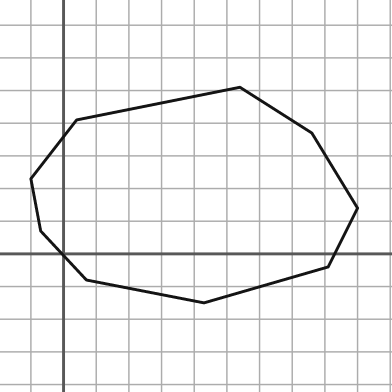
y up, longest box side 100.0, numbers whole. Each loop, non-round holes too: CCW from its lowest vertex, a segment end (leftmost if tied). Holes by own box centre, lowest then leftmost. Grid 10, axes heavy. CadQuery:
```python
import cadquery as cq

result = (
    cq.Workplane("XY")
    .moveTo(43.0, -15.0)
    .lineTo(81.0, -4.0)
    .lineTo(90.0, 14.0)
    .lineTo(76.0, 37.0)
    .lineTo(54.0, 51.0)
    .lineTo(4.0, 41.0)
    .lineTo(-10.0, 23.0)
    .lineTo(-7.0, 7.0)
    .lineTo(7.0, -8.0)
    .close()
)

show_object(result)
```